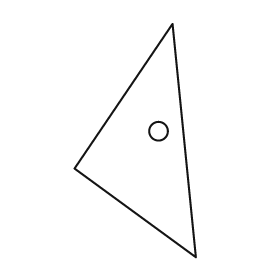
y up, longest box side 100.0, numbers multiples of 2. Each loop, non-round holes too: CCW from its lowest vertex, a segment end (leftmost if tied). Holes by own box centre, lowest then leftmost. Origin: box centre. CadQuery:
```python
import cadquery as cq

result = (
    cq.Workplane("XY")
    .moveTo(26.0, -50.0)
    .lineTo(16.0, 50.0)
    .lineTo(-26.0, -12.0)
    .close()
    .moveTo(10.0, 4.0)
    .circle(4.0)
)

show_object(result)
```